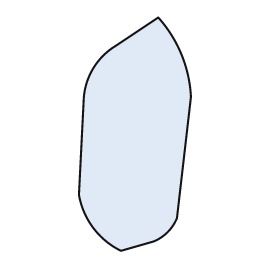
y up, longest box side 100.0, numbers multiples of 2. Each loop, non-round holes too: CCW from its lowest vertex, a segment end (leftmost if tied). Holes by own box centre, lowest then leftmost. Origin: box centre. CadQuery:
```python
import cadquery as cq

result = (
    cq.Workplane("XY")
    .moveTo(-6.0, -50.0)
    .lineTo(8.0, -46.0)
    .threePointArc((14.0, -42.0), (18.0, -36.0))
    .lineTo(24.0, 16.0)
    .threePointArc((20.0, 34.0), (10.0, 50.0))
    .lineTo(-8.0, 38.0)
    .threePointArc((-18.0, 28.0), (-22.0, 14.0))
    .lineTo(-24.0, -26.0)
    .threePointArc((-18.0, -40.0), (-6.0, -50.0))
    .close()
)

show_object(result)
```